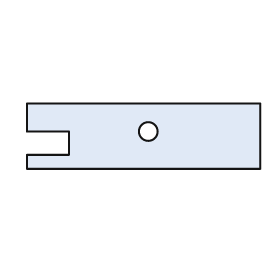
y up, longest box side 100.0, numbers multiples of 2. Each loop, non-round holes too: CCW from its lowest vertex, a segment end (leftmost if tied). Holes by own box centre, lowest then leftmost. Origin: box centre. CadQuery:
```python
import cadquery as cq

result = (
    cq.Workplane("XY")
    .moveTo(-50.0, -14.0)
    .lineTo(50.0, -14.0)
    .lineTo(50.0, 14.0)
    .lineTo(-50.0, 14.0)
    .lineTo(-50.0, 2.0)
    .lineTo(-32.0, 2.0)
    .lineTo(-32.0, -8.0)
    .lineTo(-50.0, -8.0)
    .close()
    .moveTo(2.0, 2.0)
    .circle(4.0)
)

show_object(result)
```